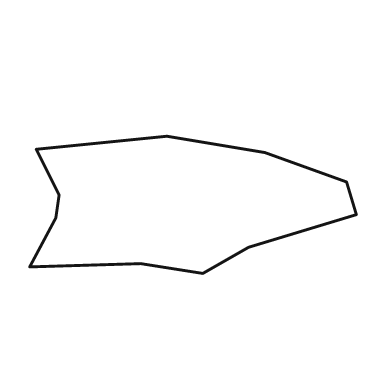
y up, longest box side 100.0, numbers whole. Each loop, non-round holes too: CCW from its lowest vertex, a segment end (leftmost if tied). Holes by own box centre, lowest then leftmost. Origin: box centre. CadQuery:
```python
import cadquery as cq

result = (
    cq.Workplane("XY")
    .moveTo(3.0, -21.0)
    .lineTo(17.0, -13.0)
    .lineTo(50.0, -3.0)
    .lineTo(47.0, 7.0)
    .lineTo(22.0, 16.0)
    .lineTo(-8.0, 21.0)
    .lineTo(-48.0, 17.0)
    .lineTo(-41.0, 3.0)
    .lineTo(-42.0, -4.0)
    .lineTo(-50.0, -19.0)
    .lineTo(-16.0, -18.0)
    .close()
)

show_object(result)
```